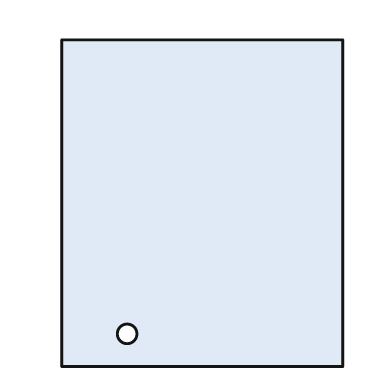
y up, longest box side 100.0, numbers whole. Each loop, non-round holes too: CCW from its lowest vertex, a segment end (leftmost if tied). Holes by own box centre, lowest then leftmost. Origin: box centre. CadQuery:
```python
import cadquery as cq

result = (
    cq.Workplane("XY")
    .moveTo(-43.0, -50.0)
    .lineTo(43.0, -50.0)
    .lineTo(43.0, 50.0)
    .lineTo(-43.0, 50.0)
    .close()
    .moveTo(-23.0, -40.0)
    .circle(3.0)
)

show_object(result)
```